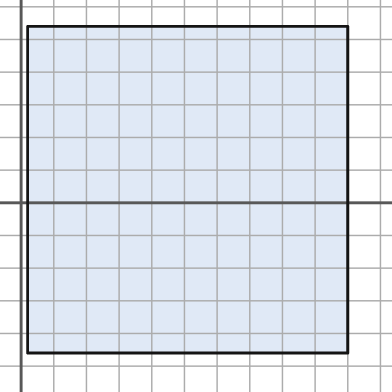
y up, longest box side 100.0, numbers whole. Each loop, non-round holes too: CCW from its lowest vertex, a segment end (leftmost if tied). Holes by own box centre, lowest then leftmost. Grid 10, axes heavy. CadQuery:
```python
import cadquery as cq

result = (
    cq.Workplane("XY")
    .moveTo(2.0, -46.0)
    .lineTo(100.0, -46.0)
    .lineTo(100.0, 54.0)
    .lineTo(2.0, 54.0)
    .close()
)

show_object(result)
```